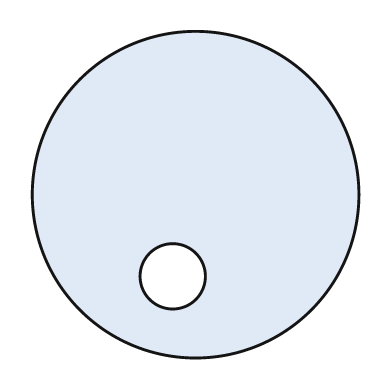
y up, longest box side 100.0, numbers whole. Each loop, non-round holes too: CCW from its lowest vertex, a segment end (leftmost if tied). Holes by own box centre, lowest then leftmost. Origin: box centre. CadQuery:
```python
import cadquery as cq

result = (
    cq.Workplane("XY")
    .moveTo(0.0, 0.0)
    .circle(50.0)
    .moveTo(-7.0, -25.0)
    .circle(10.0)
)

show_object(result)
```